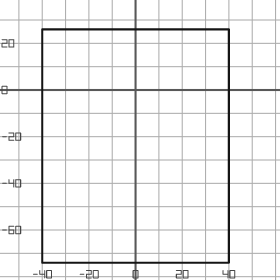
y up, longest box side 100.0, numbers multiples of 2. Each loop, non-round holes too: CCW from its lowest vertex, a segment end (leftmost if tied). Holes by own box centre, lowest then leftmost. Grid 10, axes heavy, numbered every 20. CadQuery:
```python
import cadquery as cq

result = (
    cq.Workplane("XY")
    .moveTo(-40.0, -74.0)
    .lineTo(40.0, -74.0)
    .lineTo(40.0, 26.0)
    .lineTo(-40.0, 26.0)
    .close()
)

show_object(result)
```